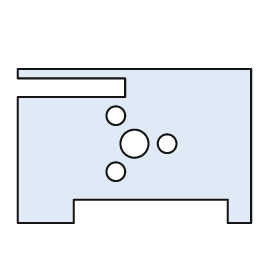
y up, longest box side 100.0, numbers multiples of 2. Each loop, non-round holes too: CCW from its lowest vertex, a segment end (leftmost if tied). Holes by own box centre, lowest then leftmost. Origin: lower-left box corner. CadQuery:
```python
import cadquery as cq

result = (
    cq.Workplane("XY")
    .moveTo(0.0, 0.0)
    .lineTo(24.0, 0.0)
    .lineTo(24.0, 10.0)
    .lineTo(90.0, 10.0)
    .lineTo(90.0, 0.0)
    .lineTo(100.0, 0.0)
    .lineTo(100.0, 66.0)
    .lineTo(0.0, 66.0)
    .lineTo(0.0, 62.0)
    .lineTo(46.0, 62.0)
    .lineTo(46.0, 54.0)
    .lineTo(0.0, 54.0)
    .close()
    .moveTo(42.0, 22.0)
    .circle(4.0)
    .moveTo(50.0, 34.0)
    .circle(6.0)
    .moveTo(64.0, 34.0)
    .circle(4.0)
    .moveTo(42.0, 46.0)
    .circle(4.0)
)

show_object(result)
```